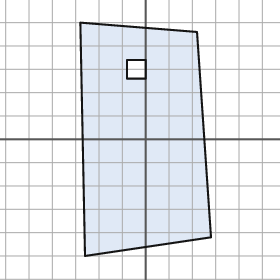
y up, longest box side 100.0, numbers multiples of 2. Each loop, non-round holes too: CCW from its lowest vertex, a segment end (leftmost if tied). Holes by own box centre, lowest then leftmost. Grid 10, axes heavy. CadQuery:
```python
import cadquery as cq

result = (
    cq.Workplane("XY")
    .moveTo(-26.0, -50.0)
    .lineTo(28.0, -42.0)
    .lineTo(22.0, 46.0)
    .lineTo(-28.0, 50.0)
    .close()
    .moveTo(-8.0, 26.0)
    .lineTo(0.0, 26.0)
    .lineTo(0.0, 34.0)
    .lineTo(-8.0, 34.0)
    .close()
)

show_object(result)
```